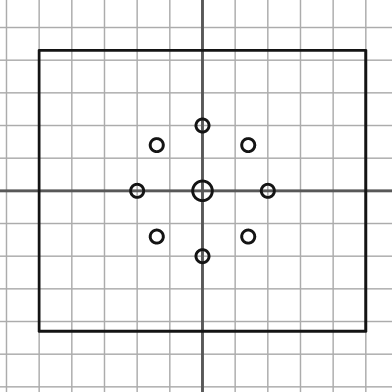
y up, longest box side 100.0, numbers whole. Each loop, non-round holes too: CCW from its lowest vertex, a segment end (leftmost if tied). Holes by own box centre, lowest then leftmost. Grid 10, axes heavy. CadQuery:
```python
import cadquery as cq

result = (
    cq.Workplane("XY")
    .moveTo(-50.0, -43.0)
    .lineTo(50.0, -43.0)
    .lineTo(50.0, 43.0)
    .lineTo(-50.0, 43.0)
    .close()
    .moveTo(0.0, -20.0)
    .circle(2.0)
    .moveTo(-14.0, -14.0)
    .circle(2.0)
    .moveTo(14.0, -14.0)
    .circle(2.0)
    .moveTo(-20.0, 0.0)
    .circle(2.0)
    .moveTo(0.0, 0.0)
    .circle(3.0)
    .moveTo(20.0, 0.0)
    .circle(2.0)
    .moveTo(-14.0, 14.0)
    .circle(2.0)
    .moveTo(14.0, 14.0)
    .circle(2.0)
    .moveTo(0.0, 20.0)
    .circle(2.0)
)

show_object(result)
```